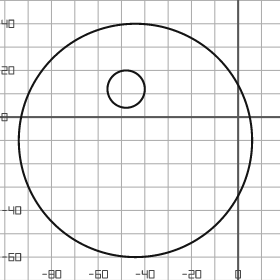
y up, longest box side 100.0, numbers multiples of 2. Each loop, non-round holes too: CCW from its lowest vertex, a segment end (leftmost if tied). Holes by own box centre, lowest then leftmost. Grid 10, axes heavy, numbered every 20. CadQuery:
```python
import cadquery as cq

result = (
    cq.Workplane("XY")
    .moveTo(-44.0, -10.0)
    .circle(50.0)
    .moveTo(-48.0, 12.0)
    .circle(8.0)
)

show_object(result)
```